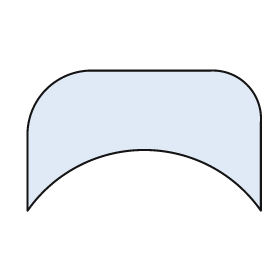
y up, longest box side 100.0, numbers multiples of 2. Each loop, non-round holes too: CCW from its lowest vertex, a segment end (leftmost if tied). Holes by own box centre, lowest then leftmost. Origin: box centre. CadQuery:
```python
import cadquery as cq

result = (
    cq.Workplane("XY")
    .moveTo(-50.0, -30.0)
    .threePointArc((0.0, -4.0), (50.0, -30.0))
    .lineTo(50.0, 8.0)
    .threePointArc((44.0, 24.0), (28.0, 30.0))
    .lineTo(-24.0, 30.0)
    .threePointArc((-42.0, 22.0), (-50.0, 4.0))
    .close()
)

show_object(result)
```